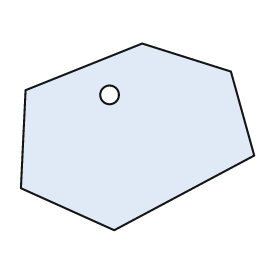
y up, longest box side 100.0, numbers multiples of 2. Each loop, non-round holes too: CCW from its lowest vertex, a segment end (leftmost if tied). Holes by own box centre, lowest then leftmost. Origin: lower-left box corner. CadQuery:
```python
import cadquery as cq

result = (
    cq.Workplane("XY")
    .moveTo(40.0, 0.0)
    .lineTo(100.0, 32.0)
    .lineTo(90.0, 68.0)
    .lineTo(52.0, 80.0)
    .lineTo(2.0, 60.0)
    .lineTo(0.0, 18.0)
    .close()
    .moveTo(38.0, 58.0)
    .circle(4.0)
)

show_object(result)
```